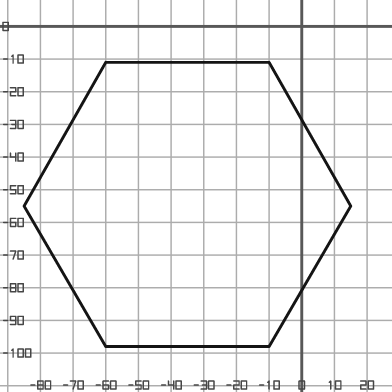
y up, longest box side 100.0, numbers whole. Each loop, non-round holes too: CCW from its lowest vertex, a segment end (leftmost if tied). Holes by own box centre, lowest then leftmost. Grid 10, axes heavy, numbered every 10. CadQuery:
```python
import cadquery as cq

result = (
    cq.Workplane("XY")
    .moveTo(-60.0, -98.0)
    .lineTo(-10.0, -98.0)
    .lineTo(15.0, -55.0)
    .lineTo(-10.0, -11.0)
    .lineTo(-60.0, -11.0)
    .lineTo(-85.0, -55.0)
    .close()
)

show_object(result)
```